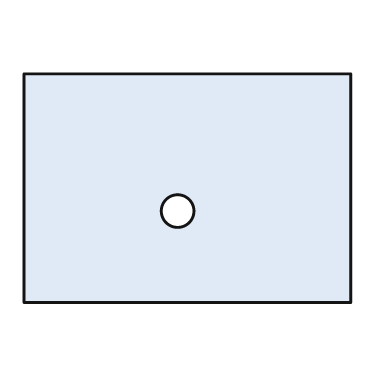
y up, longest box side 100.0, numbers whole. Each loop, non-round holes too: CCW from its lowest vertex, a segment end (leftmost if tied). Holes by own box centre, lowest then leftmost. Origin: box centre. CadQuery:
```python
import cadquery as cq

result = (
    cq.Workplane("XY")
    .moveTo(-50.0, -35.0)
    .lineTo(50.0, -35.0)
    .lineTo(50.0, 35.0)
    .lineTo(-50.0, 35.0)
    .close()
    .moveTo(-3.0, -7.0)
    .circle(5.0)
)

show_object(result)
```